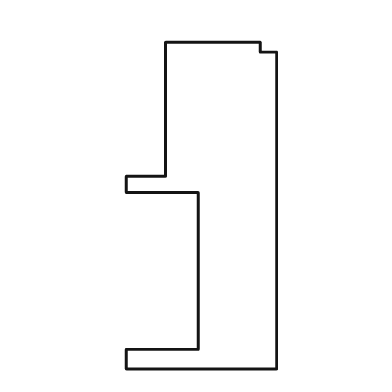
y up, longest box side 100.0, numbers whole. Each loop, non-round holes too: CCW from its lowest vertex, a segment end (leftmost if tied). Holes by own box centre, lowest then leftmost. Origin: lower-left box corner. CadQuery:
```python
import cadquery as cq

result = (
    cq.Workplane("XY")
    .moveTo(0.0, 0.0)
    .lineTo(46.0, 0.0)
    .lineTo(46.0, 97.0)
    .lineTo(41.0, 97.0)
    .lineTo(41.0, 100.0)
    .lineTo(12.0, 100.0)
    .lineTo(12.0, 59.0)
    .lineTo(0.0, 59.0)
    .lineTo(0.0, 54.0)
    .lineTo(22.0, 54.0)
    .lineTo(22.0, 6.0)
    .lineTo(0.0, 6.0)
    .close()
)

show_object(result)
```